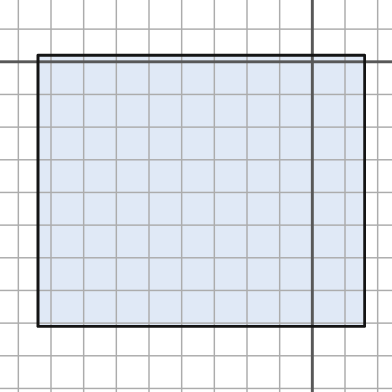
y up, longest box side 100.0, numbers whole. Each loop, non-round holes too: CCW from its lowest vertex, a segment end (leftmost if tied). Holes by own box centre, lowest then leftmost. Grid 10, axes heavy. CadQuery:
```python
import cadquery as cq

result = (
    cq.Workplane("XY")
    .moveTo(-84.0, -81.0)
    .lineTo(16.0, -81.0)
    .lineTo(16.0, 2.0)
    .lineTo(-84.0, 2.0)
    .close()
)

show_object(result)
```